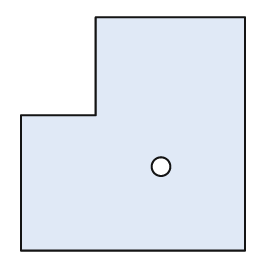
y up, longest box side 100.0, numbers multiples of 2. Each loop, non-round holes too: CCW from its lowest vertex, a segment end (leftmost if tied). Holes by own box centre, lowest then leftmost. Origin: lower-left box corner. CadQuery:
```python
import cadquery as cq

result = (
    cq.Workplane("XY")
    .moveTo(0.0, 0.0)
    .lineTo(96.0, 0.0)
    .lineTo(96.0, 100.0)
    .lineTo(32.0, 100.0)
    .lineTo(32.0, 58.0)
    .lineTo(0.0, 58.0)
    .close()
    .moveTo(60.0, 36.0)
    .circle(4.0)
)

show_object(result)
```